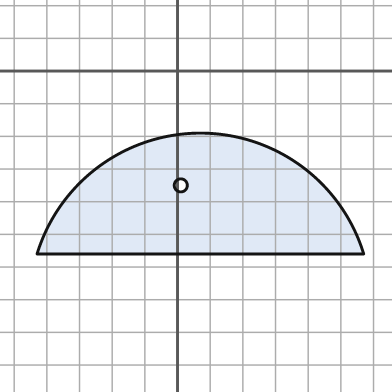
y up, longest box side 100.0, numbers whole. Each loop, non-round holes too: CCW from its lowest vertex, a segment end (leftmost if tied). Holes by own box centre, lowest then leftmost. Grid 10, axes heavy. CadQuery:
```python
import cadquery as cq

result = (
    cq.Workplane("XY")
    .moveTo(-43.0, -56.0)
    .lineTo(57.0, -56.0)
    .threePointArc((7.0, -19.0), (-43.0, -56.0))
    .close()
    .moveTo(1.0, -35.0)
    .circle(2.0)
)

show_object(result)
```